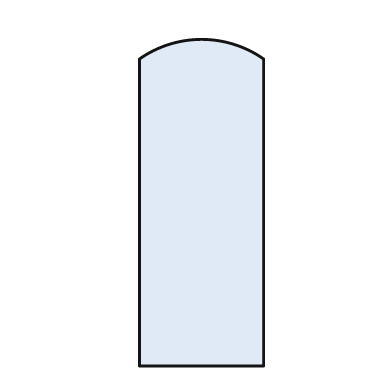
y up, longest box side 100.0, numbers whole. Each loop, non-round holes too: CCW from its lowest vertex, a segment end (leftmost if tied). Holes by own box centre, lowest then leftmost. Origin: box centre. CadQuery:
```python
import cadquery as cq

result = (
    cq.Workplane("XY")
    .moveTo(-19.0, -50.0)
    .lineTo(19.0, -50.0)
    .lineTo(19.0, 44.0)
    .threePointArc((0.0, 50.0), (-19.0, 44.0))
    .close()
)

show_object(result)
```